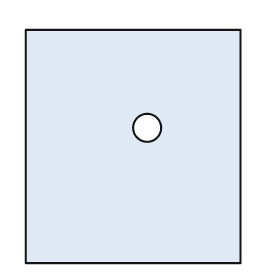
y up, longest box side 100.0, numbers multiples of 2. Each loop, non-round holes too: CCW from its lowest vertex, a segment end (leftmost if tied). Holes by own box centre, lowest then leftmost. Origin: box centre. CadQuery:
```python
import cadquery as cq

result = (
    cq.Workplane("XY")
    .moveTo(-46.0, -50.0)
    .lineTo(46.0, -50.0)
    .lineTo(46.0, 50.0)
    .lineTo(-46.0, 50.0)
    .close()
    .moveTo(6.0, 8.0)
    .circle(6.0)
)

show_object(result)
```